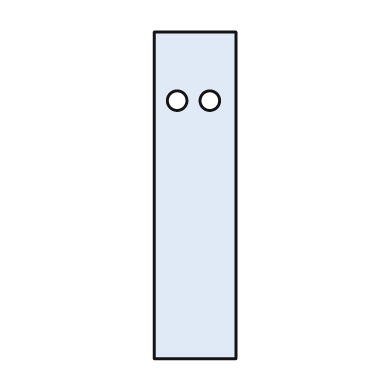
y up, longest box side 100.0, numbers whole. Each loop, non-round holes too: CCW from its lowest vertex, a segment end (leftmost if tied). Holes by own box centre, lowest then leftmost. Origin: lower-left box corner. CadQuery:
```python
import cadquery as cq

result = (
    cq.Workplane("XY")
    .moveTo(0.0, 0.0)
    .lineTo(25.0, 0.0)
    .lineTo(25.0, 100.0)
    .lineTo(0.0, 100.0)
    .close()
    .moveTo(7.0, 79.0)
    .circle(3.0)
    .moveTo(17.0, 79.0)
    .circle(3.0)
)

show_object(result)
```